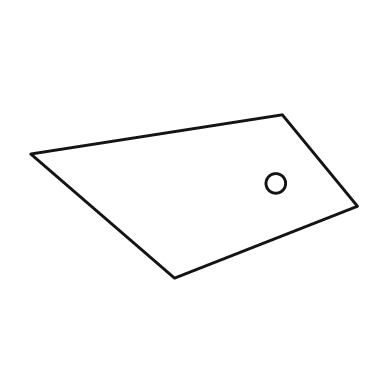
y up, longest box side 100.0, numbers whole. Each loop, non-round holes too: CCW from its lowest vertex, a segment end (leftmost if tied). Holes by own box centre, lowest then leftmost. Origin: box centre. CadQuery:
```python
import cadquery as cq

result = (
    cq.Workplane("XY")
    .moveTo(-6.0, -25.0)
    .lineTo(50.0, -3.0)
    .lineTo(27.0, 25.0)
    .lineTo(-50.0, 13.0)
    .close()
    .moveTo(25.0, 4.0)
    .circle(3.0)
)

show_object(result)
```